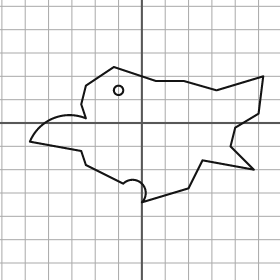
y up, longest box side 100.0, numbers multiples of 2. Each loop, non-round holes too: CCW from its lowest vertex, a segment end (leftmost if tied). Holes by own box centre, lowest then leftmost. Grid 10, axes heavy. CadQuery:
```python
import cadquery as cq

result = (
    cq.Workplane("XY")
    .moveTo(0.0, -34.0)
    .lineTo(20.0, -28.0)
    .lineTo(26.0, -16.0)
    .lineTo(48.0, -20.0)
    .lineTo(38.0, -10.0)
    .lineTo(40.0, -2.0)
    .lineTo(50.0, 4.0)
    .lineTo(52.0, 20.0)
    .lineTo(32.0, 14.0)
    .lineTo(18.0, 18.0)
    .lineTo(6.0, 18.0)
    .lineTo(-12.0, 24.0)
    .lineTo(-24.0, 16.0)
    .lineTo(-26.0, 8.0)
    .lineTo(-24.0, 2.0)
    .threePointArc((-38.0, 2.0), (-48.0, -8.0))
    .lineTo(-26.0, -12.0)
    .lineTo(-24.0, -18.0)
    .lineTo(-8.0, -26.0)
    .threePointArc((0.0, -26.0), (0.0, -34.0))
    .close()
    .moveTo(-10.0, 14.0)
    .circle(2.0)
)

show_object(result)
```